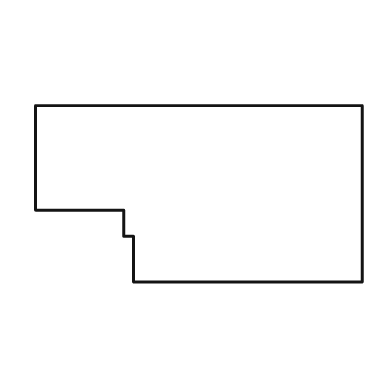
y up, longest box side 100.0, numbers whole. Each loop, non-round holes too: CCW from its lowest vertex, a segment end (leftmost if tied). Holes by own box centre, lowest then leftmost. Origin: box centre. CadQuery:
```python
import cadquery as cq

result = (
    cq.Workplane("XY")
    .moveTo(-20.0, -27.0)
    .lineTo(50.0, -27.0)
    .lineTo(50.0, 27.0)
    .lineTo(-50.0, 27.0)
    .lineTo(-50.0, -5.0)
    .lineTo(-23.0, -5.0)
    .lineTo(-23.0, -13.0)
    .lineTo(-20.0, -13.0)
    .close()
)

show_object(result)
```